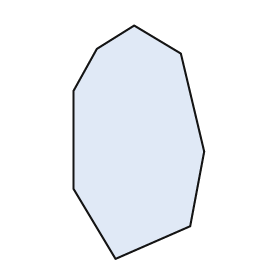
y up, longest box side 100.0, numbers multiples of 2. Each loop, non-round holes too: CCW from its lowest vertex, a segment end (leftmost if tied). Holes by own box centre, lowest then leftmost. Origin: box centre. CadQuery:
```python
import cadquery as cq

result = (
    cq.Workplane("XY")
    .moveTo(-10.0, -50.0)
    .lineTo(22.0, -36.0)
    .lineTo(28.0, -4.0)
    .lineTo(18.0, 38.0)
    .lineTo(-2.0, 50.0)
    .lineTo(-18.0, 40.0)
    .lineTo(-28.0, 22.0)
    .lineTo(-28.0, -20.0)
    .close()
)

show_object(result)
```